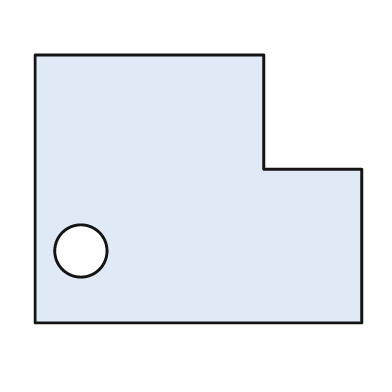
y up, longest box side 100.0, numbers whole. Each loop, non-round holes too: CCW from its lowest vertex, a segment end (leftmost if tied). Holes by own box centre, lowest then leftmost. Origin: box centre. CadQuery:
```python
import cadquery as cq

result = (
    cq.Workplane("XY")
    .moveTo(-50.0, -41.0)
    .lineTo(50.0, -41.0)
    .lineTo(50.0, 6.0)
    .lineTo(20.0, 6.0)
    .lineTo(20.0, 41.0)
    .lineTo(-50.0, 41.0)
    .close()
    .moveTo(-36.0, -19.0)
    .circle(8.0)
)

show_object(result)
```